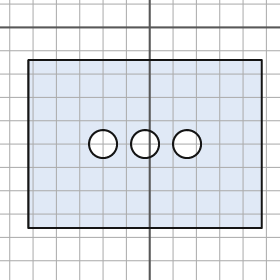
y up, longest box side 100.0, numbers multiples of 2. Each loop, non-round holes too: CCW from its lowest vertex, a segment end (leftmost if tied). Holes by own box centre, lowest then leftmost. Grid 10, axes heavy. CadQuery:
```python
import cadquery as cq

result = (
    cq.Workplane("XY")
    .moveTo(-52.0, -86.0)
    .lineTo(48.0, -86.0)
    .lineTo(48.0, -14.0)
    .lineTo(-52.0, -14.0)
    .close()
    .moveTo(-20.0, -50.0)
    .circle(6.0)
    .moveTo(-2.0, -50.0)
    .circle(6.0)
    .moveTo(16.0, -50.0)
    .circle(6.0)
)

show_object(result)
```